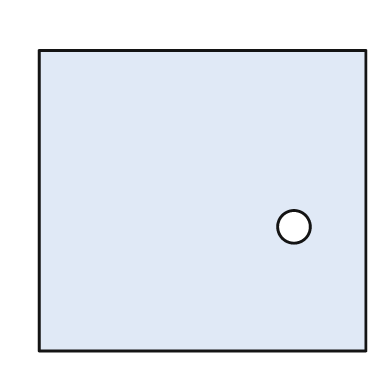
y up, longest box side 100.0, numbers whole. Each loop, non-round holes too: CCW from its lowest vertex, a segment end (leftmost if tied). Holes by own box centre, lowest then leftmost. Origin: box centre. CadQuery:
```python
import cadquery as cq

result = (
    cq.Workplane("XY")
    .moveTo(-50.0, -46.0)
    .lineTo(50.0, -46.0)
    .lineTo(50.0, 46.0)
    .lineTo(-50.0, 46.0)
    .close()
    .moveTo(28.0, -8.0)
    .circle(5.0)
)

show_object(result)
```